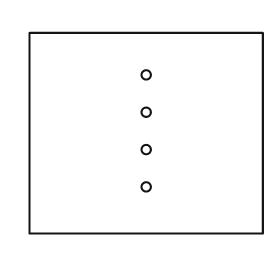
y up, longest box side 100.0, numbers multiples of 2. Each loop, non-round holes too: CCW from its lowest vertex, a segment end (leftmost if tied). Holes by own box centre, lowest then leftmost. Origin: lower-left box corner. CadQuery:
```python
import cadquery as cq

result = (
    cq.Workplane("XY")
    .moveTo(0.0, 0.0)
    .lineTo(100.0, 0.0)
    .lineTo(100.0, 86.0)
    .lineTo(0.0, 86.0)
    .close()
    .moveTo(50.0, 20.0)
    .circle(2.0)
    .moveTo(50.0, 36.0)
    .circle(2.0)
    .moveTo(50.0, 52.0)
    .circle(2.0)
    .moveTo(50.0, 68.0)
    .circle(2.0)
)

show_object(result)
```